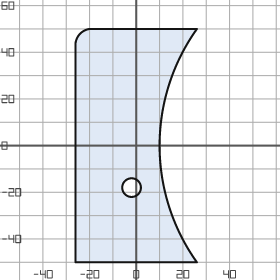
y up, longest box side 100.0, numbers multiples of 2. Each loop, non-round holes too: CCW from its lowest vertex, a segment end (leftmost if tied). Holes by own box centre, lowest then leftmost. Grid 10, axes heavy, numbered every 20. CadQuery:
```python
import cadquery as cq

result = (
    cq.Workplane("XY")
    .moveTo(-26.0, -50.0)
    .lineTo(26.0, -50.0)
    .threePointArc((10.0, 0.0), (26.0, 50.0))
    .lineTo(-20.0, 50.0)
    .threePointArc((-24.0, 48.0), (-26.0, 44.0))
    .close()
    .moveTo(-2.0, -18.0)
    .circle(4.0)
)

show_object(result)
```